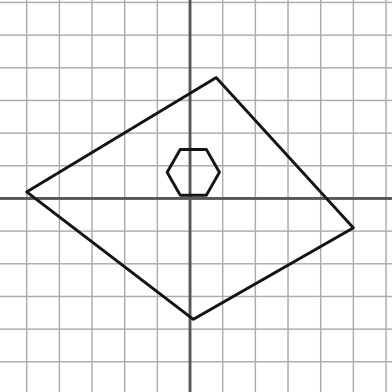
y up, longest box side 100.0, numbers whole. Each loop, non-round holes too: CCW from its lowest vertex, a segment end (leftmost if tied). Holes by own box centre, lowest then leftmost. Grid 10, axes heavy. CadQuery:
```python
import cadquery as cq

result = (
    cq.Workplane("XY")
    .moveTo(1.0, -37.0)
    .lineTo(50.0, -9.0)
    .lineTo(8.0, 37.0)
    .lineTo(-50.0, 2.0)
    .close()
    .moveTo(-3.0, 1.0)
    .lineTo(5.0, 1.0)
    .lineTo(9.0, 8.0)
    .lineTo(5.0, 15.0)
    .lineTo(-3.0, 15.0)
    .lineTo(-7.0, 8.0)
    .close()
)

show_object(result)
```